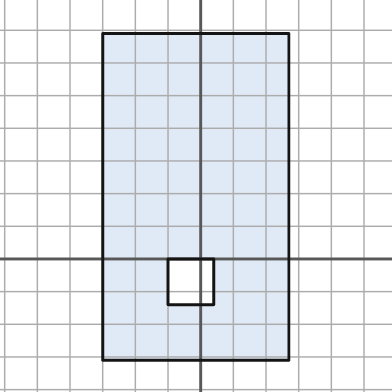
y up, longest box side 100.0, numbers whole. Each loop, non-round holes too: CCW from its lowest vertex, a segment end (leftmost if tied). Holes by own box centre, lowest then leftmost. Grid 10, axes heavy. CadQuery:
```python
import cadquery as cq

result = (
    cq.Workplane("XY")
    .moveTo(-30.0, -31.0)
    .lineTo(27.0, -31.0)
    .lineTo(27.0, 69.0)
    .lineTo(-30.0, 69.0)
    .close()
    .moveTo(-10.0, -14.0)
    .lineTo(4.0, -14.0)
    .lineTo(4.0, 0.0)
    .lineTo(-10.0, 0.0)
    .close()
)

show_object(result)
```